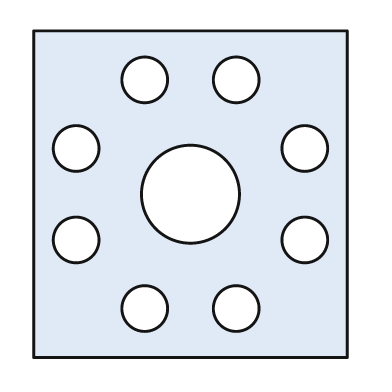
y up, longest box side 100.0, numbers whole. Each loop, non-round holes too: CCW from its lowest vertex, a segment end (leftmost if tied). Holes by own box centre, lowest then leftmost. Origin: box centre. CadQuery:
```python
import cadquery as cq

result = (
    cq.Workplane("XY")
    .moveTo(-48.0, -50.0)
    .lineTo(48.0, -50.0)
    .lineTo(48.0, 50.0)
    .lineTo(-48.0, 50.0)
    .close()
    .moveTo(-14.0, -35.0)
    .circle(7.0)
    .moveTo(14.0, -35.0)
    .circle(7.0)
    .moveTo(-35.0, -14.0)
    .circle(7.0)
    .moveTo(35.0, -14.0)
    .circle(7.0)
    .moveTo(0.0, 0.0)
    .circle(15.0)
    .moveTo(-35.0, 14.0)
    .circle(7.0)
    .moveTo(35.0, 14.0)
    .circle(7.0)
    .moveTo(-14.0, 35.0)
    .circle(7.0)
    .moveTo(14.0, 35.0)
    .circle(7.0)
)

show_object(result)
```